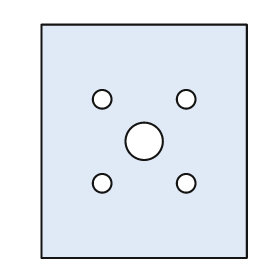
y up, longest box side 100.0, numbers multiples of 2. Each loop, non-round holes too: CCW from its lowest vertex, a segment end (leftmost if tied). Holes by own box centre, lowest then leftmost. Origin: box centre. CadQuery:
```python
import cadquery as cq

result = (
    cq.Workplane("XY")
    .moveTo(-44.0, -50.0)
    .lineTo(44.0, -50.0)
    .lineTo(44.0, 50.0)
    .lineTo(-44.0, 50.0)
    .close()
    .moveTo(-18.0, -18.0)
    .circle(4.0)
    .moveTo(18.0, -18.0)
    .circle(4.0)
    .moveTo(0.0, 0.0)
    .circle(8.0)
    .moveTo(-18.0, 18.0)
    .circle(4.0)
    .moveTo(18.0, 18.0)
    .circle(4.0)
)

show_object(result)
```